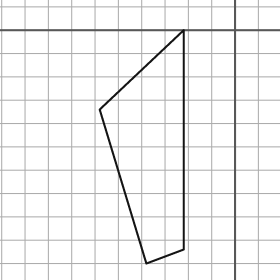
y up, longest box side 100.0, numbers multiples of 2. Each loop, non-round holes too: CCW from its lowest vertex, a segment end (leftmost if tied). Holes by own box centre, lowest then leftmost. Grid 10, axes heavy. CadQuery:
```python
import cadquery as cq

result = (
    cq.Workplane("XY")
    .moveTo(-38.0, -100.0)
    .lineTo(-22.0, -94.0)
    .lineTo(-22.0, 0.0)
    .lineTo(-58.0, -34.0)
    .close()
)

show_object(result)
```